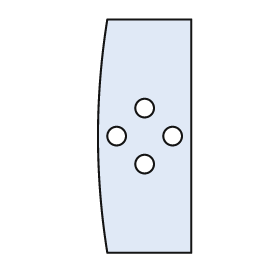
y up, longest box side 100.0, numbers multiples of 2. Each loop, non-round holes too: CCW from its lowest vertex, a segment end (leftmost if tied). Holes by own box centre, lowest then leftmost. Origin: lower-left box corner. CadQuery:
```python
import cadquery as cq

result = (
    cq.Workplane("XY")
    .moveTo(4.0, 0.0)
    .lineTo(40.0, 0.0)
    .lineTo(40.0, 100.0)
    .lineTo(4.0, 100.0)
    .threePointArc((0.0, 50.0), (4.0, 0.0))
    .close()
    .moveTo(20.0, 38.0)
    .circle(4.0)
    .moveTo(8.0, 50.0)
    .circle(4.0)
    .moveTo(32.0, 50.0)
    .circle(4.0)
    .moveTo(20.0, 62.0)
    .circle(4.0)
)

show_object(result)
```